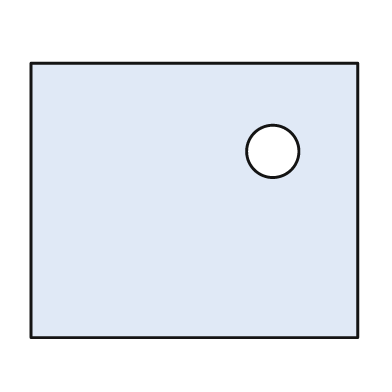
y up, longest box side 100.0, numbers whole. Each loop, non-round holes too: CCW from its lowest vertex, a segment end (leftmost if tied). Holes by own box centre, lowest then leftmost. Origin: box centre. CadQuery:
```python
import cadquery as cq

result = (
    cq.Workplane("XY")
    .moveTo(-50.0, -42.0)
    .lineTo(50.0, -42.0)
    .lineTo(50.0, 42.0)
    .lineTo(-50.0, 42.0)
    .close()
    .moveTo(24.0, 15.0)
    .circle(8.0)
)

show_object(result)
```